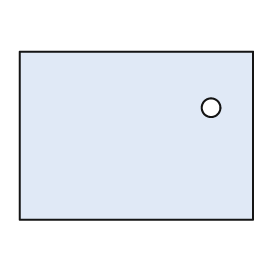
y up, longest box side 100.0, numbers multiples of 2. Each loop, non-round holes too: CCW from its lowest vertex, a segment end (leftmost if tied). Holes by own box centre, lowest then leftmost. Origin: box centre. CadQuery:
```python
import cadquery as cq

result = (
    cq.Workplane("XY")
    .moveTo(-50.0, -36.0)
    .lineTo(50.0, -36.0)
    .lineTo(50.0, 36.0)
    .lineTo(-50.0, 36.0)
    .close()
    .moveTo(32.0, 12.0)
    .circle(4.0)
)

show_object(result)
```